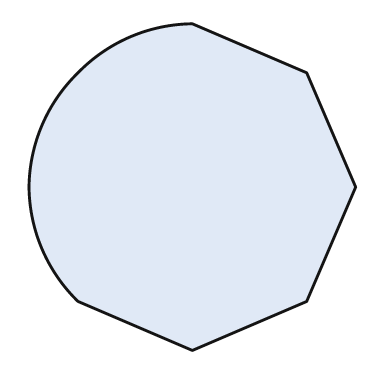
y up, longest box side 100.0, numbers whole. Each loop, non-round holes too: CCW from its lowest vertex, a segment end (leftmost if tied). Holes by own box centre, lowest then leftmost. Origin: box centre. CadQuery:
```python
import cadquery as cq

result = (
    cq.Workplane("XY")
    .moveTo(0.0, -50.0)
    .lineTo(35.0, -35.0)
    .lineTo(50.0, 0.0)
    .lineTo(35.0, 35.0)
    .lineTo(0.0, 50.0)
    .threePointArc((-19.0, 46.0), (-35.0, 35.0))
    .threePointArc((-46.0, 19.0), (-50.0, 0.0))
    .threePointArc((-46.0, -19.0), (-35.0, -35.0))
    .close()
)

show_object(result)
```